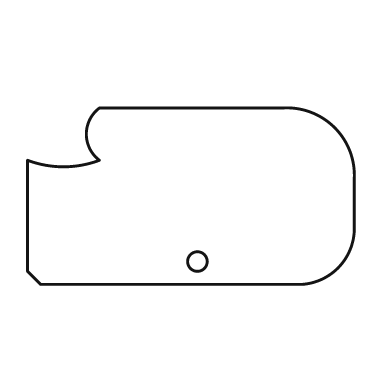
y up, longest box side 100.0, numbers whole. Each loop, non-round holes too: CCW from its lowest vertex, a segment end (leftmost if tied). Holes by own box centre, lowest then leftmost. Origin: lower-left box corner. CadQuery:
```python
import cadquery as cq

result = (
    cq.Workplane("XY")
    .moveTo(4.0, 0.0)
    .lineTo(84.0, 0.0)
    .threePointArc((95.0, 5.0), (100.0, 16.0))
    .lineTo(100.0, 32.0)
    .threePointArc((94.0, 48.0), (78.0, 54.0))
    .lineTo(22.0, 54.0)
    .threePointArc((18.0, 46.0), (22.0, 38.0))
    .threePointArc((11.0, 36.0), (0.0, 38.0))
    .lineTo(0.0, 4.0)
    .close()
    .moveTo(52.0, 7.0)
    .circle(3.0)
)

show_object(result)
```